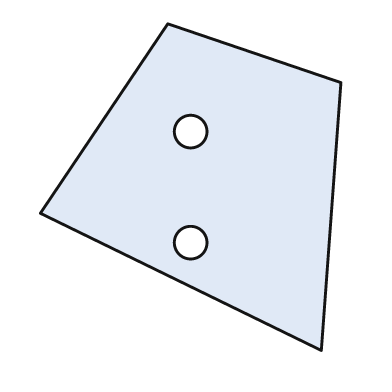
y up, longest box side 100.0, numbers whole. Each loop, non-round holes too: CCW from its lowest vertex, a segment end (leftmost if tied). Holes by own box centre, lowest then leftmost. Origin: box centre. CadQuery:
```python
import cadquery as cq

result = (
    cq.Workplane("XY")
    .moveTo(40.0, -50.0)
    .lineTo(46.0, 32.0)
    .lineTo(-7.0, 50.0)
    .lineTo(-46.0, -8.0)
    .close()
    .moveTo(0.0, -17.0)
    .circle(5.0)
    .moveTo(0.0, 17.0)
    .circle(5.0)
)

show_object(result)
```